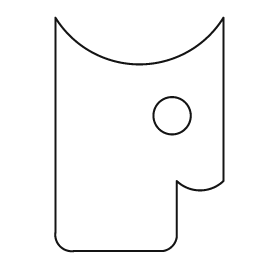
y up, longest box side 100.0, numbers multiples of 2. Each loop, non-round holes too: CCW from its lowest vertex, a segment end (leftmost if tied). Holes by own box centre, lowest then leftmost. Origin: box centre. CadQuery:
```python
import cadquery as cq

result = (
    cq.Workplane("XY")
    .moveTo(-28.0, -50.0)
    .lineTo(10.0, -50.0)
    .threePointArc((14.0, -48.0), (16.0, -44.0))
    .lineTo(16.0, -20.0)
    .threePointArc((26.0, -24.0), (36.0, -20.0))
    .lineTo(36.0, 50.0)
    .threePointArc((0.0, 30.0), (-36.0, 50.0))
    .lineTo(-36.0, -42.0)
    .threePointArc((-34.0, -48.0), (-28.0, -50.0))
    .close()
    .moveTo(14.0, 8.0)
    .circle(8.0)
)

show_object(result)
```